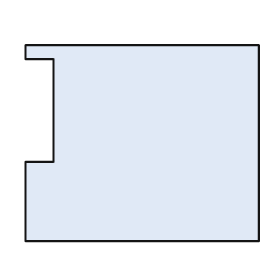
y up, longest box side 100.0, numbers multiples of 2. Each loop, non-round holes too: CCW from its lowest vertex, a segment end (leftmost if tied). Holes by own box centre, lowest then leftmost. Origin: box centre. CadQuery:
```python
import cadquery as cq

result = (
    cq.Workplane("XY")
    .moveTo(-50.0, -42.0)
    .lineTo(50.0, -42.0)
    .lineTo(50.0, 42.0)
    .lineTo(-50.0, 42.0)
    .lineTo(-50.0, 36.0)
    .lineTo(-38.0, 36.0)
    .lineTo(-38.0, -8.0)
    .lineTo(-50.0, -8.0)
    .close()
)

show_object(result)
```